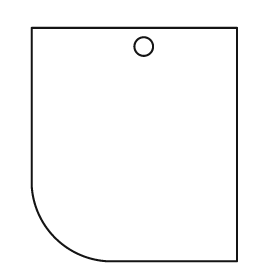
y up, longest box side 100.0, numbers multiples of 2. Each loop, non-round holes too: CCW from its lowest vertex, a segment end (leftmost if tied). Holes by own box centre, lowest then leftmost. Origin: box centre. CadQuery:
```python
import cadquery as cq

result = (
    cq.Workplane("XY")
    .moveTo(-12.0, -50.0)
    .lineTo(44.0, -50.0)
    .lineTo(44.0, 50.0)
    .lineTo(-44.0, 50.0)
    .lineTo(-44.0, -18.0)
    .threePointArc((-34.0, -40.0), (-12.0, -50.0))
    .close()
    .moveTo(4.0, 42.0)
    .circle(4.0)
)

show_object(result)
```